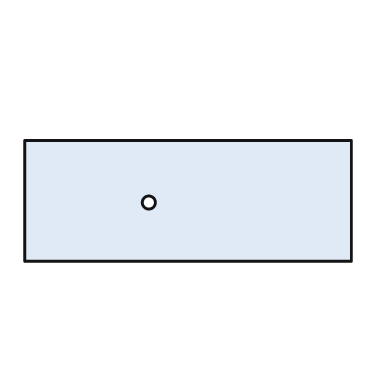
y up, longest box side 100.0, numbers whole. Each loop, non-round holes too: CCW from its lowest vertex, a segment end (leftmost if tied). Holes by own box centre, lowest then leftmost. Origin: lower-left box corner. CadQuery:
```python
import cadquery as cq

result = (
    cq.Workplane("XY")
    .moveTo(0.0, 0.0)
    .lineTo(100.0, 0.0)
    .lineTo(100.0, 37.0)
    .lineTo(0.0, 37.0)
    .close()
    .moveTo(38.0, 18.0)
    .circle(2.0)
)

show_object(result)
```